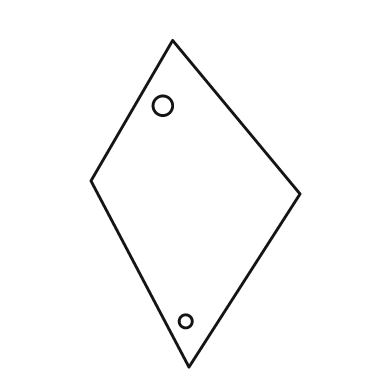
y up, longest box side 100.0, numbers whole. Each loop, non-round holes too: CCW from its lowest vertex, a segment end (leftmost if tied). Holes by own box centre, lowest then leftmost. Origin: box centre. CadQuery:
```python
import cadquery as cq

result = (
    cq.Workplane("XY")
    .moveTo(-2.0, -50.0)
    .lineTo(32.0, 3.0)
    .lineTo(-7.0, 50.0)
    .lineTo(-32.0, 7.0)
    .close()
    .moveTo(-3.0, -36.0)
    .circle(2.0)
    .moveTo(-10.0, 30.0)
    .circle(3.0)
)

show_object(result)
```